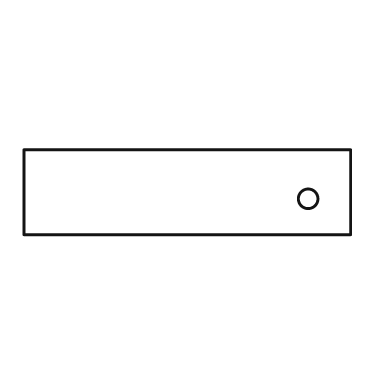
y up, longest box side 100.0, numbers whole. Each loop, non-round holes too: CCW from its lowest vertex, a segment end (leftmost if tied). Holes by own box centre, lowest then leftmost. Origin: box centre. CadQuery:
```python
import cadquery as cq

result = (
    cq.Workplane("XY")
    .moveTo(-50.0, -13.0)
    .lineTo(50.0, -13.0)
    .lineTo(50.0, 13.0)
    .lineTo(-50.0, 13.0)
    .close()
    .moveTo(37.0, -2.0)
    .circle(3.0)
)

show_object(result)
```